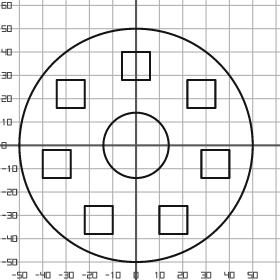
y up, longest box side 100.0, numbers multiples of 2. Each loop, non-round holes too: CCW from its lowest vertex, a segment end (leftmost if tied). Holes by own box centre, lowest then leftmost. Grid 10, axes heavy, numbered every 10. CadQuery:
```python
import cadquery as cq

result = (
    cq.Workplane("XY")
    .moveTo(0.0, 0.0)
    .circle(50.0)
    .moveTo(-22.0, -38.0)
    .lineTo(-10.0, -38.0)
    .lineTo(-10.0, -26.0)
    .lineTo(-22.0, -26.0)
    .close()
    .moveTo(10.0, -38.0)
    .lineTo(22.0, -38.0)
    .lineTo(22.0, -26.0)
    .lineTo(10.0, -26.0)
    .close()
    .moveTo(-40.0, -14.0)
    .lineTo(-28.0, -14.0)
    .lineTo(-28.0, -2.0)
    .lineTo(-40.0, -2.0)
    .close()
    .moveTo(28.0, -14.0)
    .lineTo(40.0, -14.0)
    .lineTo(40.0, -2.0)
    .lineTo(28.0, -2.0)
    .close()
    .moveTo(0.0, 0.0)
    .circle(14.0)
    .moveTo(-34.0, 16.0)
    .lineTo(-22.0, 16.0)
    .lineTo(-22.0, 28.0)
    .lineTo(-34.0, 28.0)
    .close()
    .moveTo(22.0, 16.0)
    .lineTo(34.0, 16.0)
    .lineTo(34.0, 28.0)
    .lineTo(22.0, 28.0)
    .close()
    .moveTo(-6.0, 28.0)
    .lineTo(6.0, 28.0)
    .lineTo(6.0, 40.0)
    .lineTo(-6.0, 40.0)
    .close()
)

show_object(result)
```